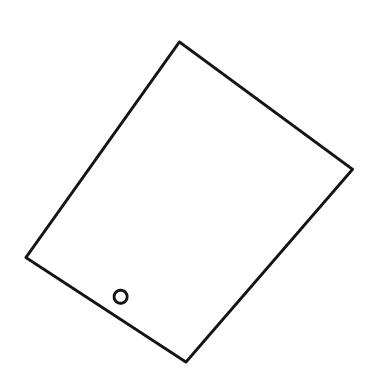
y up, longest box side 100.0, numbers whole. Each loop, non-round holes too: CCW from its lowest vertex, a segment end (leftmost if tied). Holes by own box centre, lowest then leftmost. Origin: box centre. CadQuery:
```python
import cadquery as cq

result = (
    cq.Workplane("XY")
    .moveTo(-1.0, -49.0)
    .lineTo(50.0, 10.0)
    .lineTo(-3.0, 49.0)
    .lineTo(-50.0, -17.0)
    .close()
    .moveTo(-21.0, -29.0)
    .circle(2.0)
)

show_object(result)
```